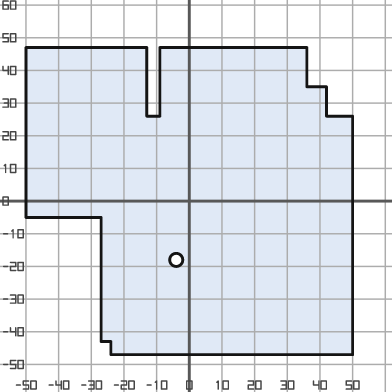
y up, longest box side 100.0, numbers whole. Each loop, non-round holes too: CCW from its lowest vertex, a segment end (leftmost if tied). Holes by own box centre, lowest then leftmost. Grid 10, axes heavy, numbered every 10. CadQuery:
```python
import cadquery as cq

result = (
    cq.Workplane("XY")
    .moveTo(-24.0, -47.0)
    .lineTo(50.0, -47.0)
    .lineTo(50.0, 26.0)
    .lineTo(42.0, 26.0)
    .lineTo(42.0, 35.0)
    .lineTo(36.0, 35.0)
    .lineTo(36.0, 47.0)
    .lineTo(-9.0, 47.0)
    .lineTo(-9.0, 26.0)
    .lineTo(-13.0, 26.0)
    .lineTo(-13.0, 47.0)
    .lineTo(-50.0, 47.0)
    .lineTo(-50.0, -5.0)
    .lineTo(-27.0, -5.0)
    .lineTo(-27.0, -43.0)
    .lineTo(-24.0, -43.0)
    .close()
    .moveTo(-4.0, -18.0)
    .circle(2.0)
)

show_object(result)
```